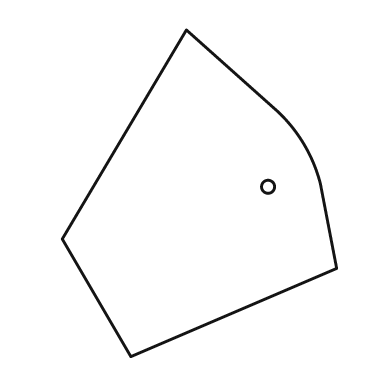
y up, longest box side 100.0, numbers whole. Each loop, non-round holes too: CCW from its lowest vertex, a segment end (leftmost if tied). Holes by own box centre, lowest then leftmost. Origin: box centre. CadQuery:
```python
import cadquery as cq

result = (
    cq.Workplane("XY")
    .moveTo(-21.0, -50.0)
    .lineTo(42.0, -23.0)
    .lineTo(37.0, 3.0)
    .threePointArc((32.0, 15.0), (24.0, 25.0))
    .lineTo(-4.0, 50.0)
    .lineTo(-42.0, -14.0)
    .close()
    .moveTo(21.0, 2.0)
    .circle(2.0)
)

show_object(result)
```